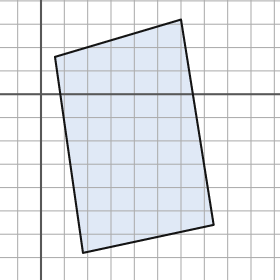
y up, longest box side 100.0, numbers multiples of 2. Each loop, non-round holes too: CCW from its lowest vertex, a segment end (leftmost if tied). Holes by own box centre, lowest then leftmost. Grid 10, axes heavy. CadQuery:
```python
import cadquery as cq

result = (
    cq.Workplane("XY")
    .moveTo(18.0, -68.0)
    .lineTo(74.0, -56.0)
    .lineTo(60.0, 32.0)
    .lineTo(6.0, 16.0)
    .close()
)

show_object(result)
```